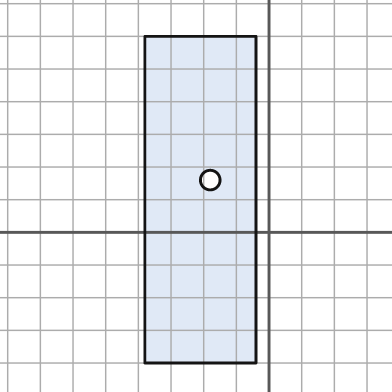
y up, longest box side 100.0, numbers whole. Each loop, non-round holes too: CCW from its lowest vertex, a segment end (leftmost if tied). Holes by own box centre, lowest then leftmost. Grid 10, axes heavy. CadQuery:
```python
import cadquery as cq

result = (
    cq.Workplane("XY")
    .moveTo(-38.0, -40.0)
    .lineTo(-4.0, -40.0)
    .lineTo(-4.0, 60.0)
    .lineTo(-38.0, 60.0)
    .close()
    .moveTo(-18.0, 16.0)
    .circle(3.0)
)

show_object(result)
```